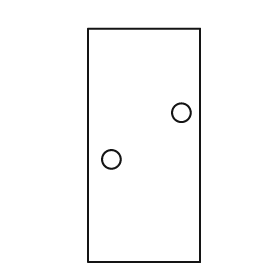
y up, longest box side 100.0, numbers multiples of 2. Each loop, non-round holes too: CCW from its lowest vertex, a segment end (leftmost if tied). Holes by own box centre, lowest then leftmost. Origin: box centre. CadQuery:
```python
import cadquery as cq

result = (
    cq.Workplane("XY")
    .moveTo(-24.0, -50.0)
    .lineTo(24.0, -50.0)
    .lineTo(24.0, 50.0)
    .lineTo(-24.0, 50.0)
    .close()
    .moveTo(-14.0, -6.0)
    .circle(4.0)
    .moveTo(16.0, 14.0)
    .circle(4.0)
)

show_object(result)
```